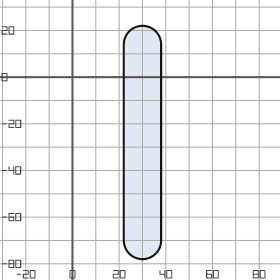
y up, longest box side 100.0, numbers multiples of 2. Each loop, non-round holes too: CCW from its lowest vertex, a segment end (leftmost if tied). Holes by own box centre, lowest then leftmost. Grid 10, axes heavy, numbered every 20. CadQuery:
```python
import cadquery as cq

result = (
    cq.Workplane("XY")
    .moveTo(22.0, -70.0)
    .threePointArc((30.0, -78.0), (38.0, -70.0))
    .lineTo(38.0, 14.0)
    .threePointArc((30.0, 22.0), (22.0, 14.0))
    .close()
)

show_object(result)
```